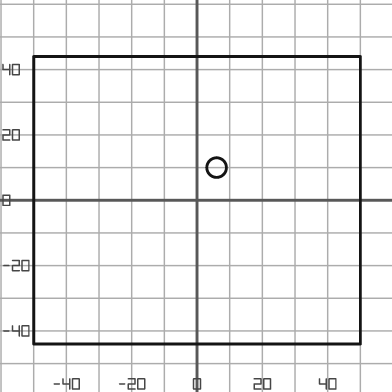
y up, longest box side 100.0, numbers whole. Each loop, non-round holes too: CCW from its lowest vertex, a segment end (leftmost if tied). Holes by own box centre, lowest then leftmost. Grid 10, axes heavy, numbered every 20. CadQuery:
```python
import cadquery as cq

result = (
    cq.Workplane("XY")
    .moveTo(-50.0, -44.0)
    .lineTo(50.0, -44.0)
    .lineTo(50.0, 44.0)
    .lineTo(-50.0, 44.0)
    .close()
    .moveTo(6.0, 10.0)
    .circle(3.0)
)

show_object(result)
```